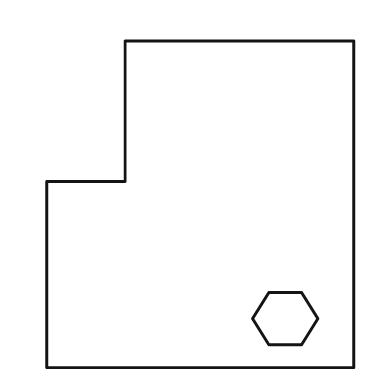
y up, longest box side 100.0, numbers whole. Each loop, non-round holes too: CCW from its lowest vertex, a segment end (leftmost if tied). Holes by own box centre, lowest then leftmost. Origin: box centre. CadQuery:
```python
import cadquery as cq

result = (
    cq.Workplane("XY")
    .moveTo(-47.0, -50.0)
    .lineTo(47.0, -50.0)
    .lineTo(47.0, 50.0)
    .lineTo(-23.0, 50.0)
    .lineTo(-23.0, 7.0)
    .lineTo(-47.0, 7.0)
    .close()
    .moveTo(21.0, -43.0)
    .lineTo(31.0, -43.0)
    .lineTo(36.0, -35.0)
    .lineTo(31.0, -27.0)
    .lineTo(21.0, -27.0)
    .lineTo(16.0, -35.0)
    .close()
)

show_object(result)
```